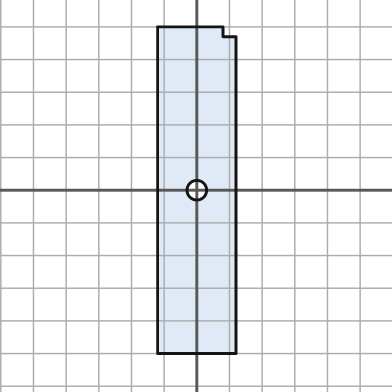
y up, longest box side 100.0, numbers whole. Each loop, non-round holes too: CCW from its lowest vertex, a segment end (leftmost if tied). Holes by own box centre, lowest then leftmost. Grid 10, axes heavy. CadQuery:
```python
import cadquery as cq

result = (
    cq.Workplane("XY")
    .moveTo(-12.0, -50.0)
    .lineTo(12.0, -50.0)
    .lineTo(12.0, 47.0)
    .lineTo(8.0, 47.0)
    .lineTo(8.0, 50.0)
    .lineTo(-12.0, 50.0)
    .close()
    .moveTo(0.0, 0.0)
    .circle(3.0)
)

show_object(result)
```